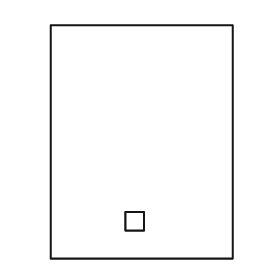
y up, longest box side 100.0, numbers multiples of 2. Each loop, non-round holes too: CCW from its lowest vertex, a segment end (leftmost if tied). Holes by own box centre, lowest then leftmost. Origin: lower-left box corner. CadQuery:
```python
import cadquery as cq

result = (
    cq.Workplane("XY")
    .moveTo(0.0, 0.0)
    .lineTo(78.0, 0.0)
    .lineTo(78.0, 100.0)
    .lineTo(0.0, 100.0)
    .close()
    .moveTo(32.0, 12.0)
    .lineTo(40.0, 12.0)
    .lineTo(40.0, 20.0)
    .lineTo(32.0, 20.0)
    .close()
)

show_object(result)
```